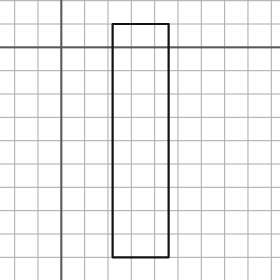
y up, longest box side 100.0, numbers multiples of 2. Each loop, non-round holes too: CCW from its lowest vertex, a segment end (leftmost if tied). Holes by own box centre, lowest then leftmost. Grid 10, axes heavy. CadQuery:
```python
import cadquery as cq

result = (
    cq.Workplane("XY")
    .moveTo(22.0, -90.0)
    .lineTo(46.0, -90.0)
    .lineTo(46.0, 10.0)
    .lineTo(22.0, 10.0)
    .close()
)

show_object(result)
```